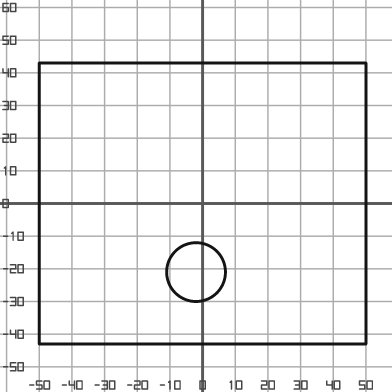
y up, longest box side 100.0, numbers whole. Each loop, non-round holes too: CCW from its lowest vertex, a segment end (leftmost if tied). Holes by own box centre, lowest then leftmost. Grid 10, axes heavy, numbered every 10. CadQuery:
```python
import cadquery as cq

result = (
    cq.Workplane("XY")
    .moveTo(-50.0, -43.0)
    .lineTo(50.0, -43.0)
    .lineTo(50.0, 43.0)
    .lineTo(-50.0, 43.0)
    .close()
    .moveTo(-2.0, -21.0)
    .circle(9.0)
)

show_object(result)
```